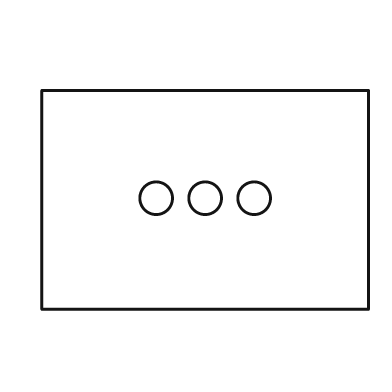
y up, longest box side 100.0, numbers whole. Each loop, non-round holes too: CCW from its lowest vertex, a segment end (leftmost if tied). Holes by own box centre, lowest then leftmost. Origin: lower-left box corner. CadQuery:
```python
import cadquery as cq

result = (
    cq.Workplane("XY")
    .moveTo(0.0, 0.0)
    .lineTo(100.0, 0.0)
    .lineTo(100.0, 67.0)
    .lineTo(0.0, 67.0)
    .close()
    .moveTo(35.0, 34.0)
    .circle(5.0)
    .moveTo(50.0, 34.0)
    .circle(5.0)
    .moveTo(65.0, 34.0)
    .circle(5.0)
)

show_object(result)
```